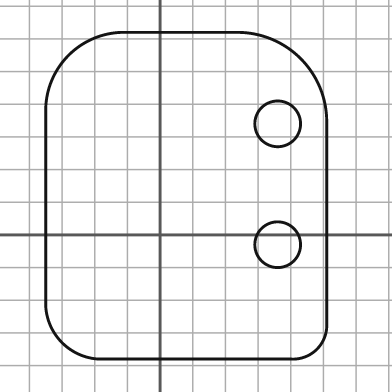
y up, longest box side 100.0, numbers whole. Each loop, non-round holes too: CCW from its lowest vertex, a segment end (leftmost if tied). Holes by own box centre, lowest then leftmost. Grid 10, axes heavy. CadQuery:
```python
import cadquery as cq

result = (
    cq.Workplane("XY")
    .moveTo(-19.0, -38.0)
    .lineTo(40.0, -38.0)
    .threePointArc((48.0, -35.0), (51.0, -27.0))
    .lineTo(51.0, 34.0)
    .threePointArc((43.0, 54.0), (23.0, 62.0))
    .lineTo(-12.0, 62.0)
    .threePointArc((-28.0, 55.0), (-35.0, 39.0))
    .lineTo(-35.0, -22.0)
    .threePointArc((-30.0, -33.0), (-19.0, -38.0))
    .close()
    .moveTo(36.0, -3.0)
    .circle(7.0)
    .moveTo(36.0, 34.0)
    .circle(7.0)
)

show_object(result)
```